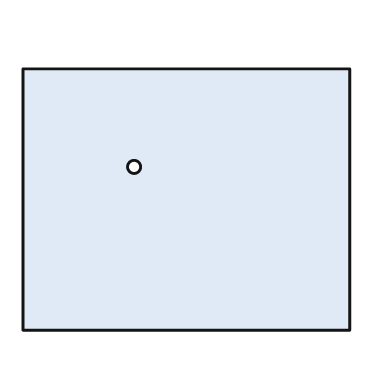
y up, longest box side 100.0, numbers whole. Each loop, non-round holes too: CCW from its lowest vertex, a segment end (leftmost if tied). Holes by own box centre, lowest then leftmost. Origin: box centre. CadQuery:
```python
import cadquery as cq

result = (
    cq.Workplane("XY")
    .moveTo(-50.0, -40.0)
    .lineTo(50.0, -40.0)
    .lineTo(50.0, 40.0)
    .lineTo(-50.0, 40.0)
    .close()
    .moveTo(-16.0, 10.0)
    .circle(2.0)
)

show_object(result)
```